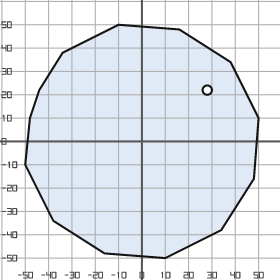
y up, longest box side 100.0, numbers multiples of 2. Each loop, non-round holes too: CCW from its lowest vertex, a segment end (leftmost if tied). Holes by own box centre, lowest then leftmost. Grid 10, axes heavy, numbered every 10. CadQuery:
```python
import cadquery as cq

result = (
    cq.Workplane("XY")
    .moveTo(10.0, -50.0)
    .lineTo(34.0, -38.0)
    .lineTo(48.0, -16.0)
    .lineTo(50.0, 10.0)
    .lineTo(38.0, 34.0)
    .lineTo(16.0, 48.0)
    .lineTo(-10.0, 50.0)
    .lineTo(-34.0, 38.0)
    .lineTo(-44.0, 22.0)
    .lineTo(-48.0, 10.0)
    .lineTo(-50.0, -10.0)
    .lineTo(-38.0, -34.0)
    .lineTo(-16.0, -48.0)
    .close()
    .moveTo(28.0, 22.0)
    .circle(2.0)
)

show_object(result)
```